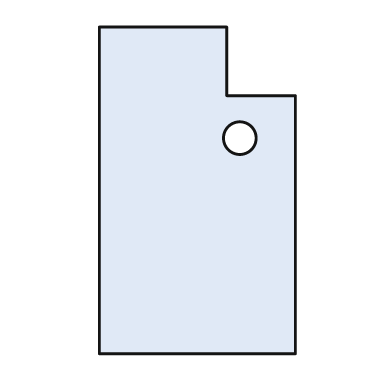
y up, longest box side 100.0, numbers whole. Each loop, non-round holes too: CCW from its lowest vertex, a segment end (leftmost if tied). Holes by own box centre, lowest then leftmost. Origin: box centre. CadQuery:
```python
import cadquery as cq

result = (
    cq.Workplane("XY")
    .moveTo(-30.0, -50.0)
    .lineTo(30.0, -50.0)
    .lineTo(30.0, 29.0)
    .lineTo(9.0, 29.0)
    .lineTo(9.0, 50.0)
    .lineTo(-30.0, 50.0)
    .close()
    .moveTo(13.0, 16.0)
    .circle(5.0)
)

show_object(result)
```